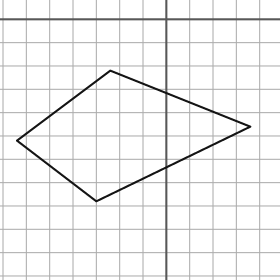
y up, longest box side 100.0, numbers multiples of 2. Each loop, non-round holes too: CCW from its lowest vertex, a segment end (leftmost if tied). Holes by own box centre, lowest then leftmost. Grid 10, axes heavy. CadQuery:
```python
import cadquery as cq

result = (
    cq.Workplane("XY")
    .moveTo(-30.0, -78.0)
    .lineTo(36.0, -46.0)
    .lineTo(-24.0, -22.0)
    .lineTo(-64.0, -52.0)
    .close()
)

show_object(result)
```